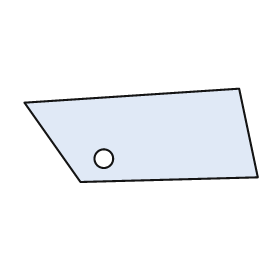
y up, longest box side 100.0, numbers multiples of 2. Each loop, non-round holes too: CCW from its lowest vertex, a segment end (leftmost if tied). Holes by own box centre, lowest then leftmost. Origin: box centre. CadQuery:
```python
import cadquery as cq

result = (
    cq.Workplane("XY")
    .moveTo(-26.0, -20.0)
    .lineTo(50.0, -18.0)
    .lineTo(42.0, 20.0)
    .lineTo(-50.0, 14.0)
    .close()
    .moveTo(-16.0, -10.0)
    .circle(4.0)
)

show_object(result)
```